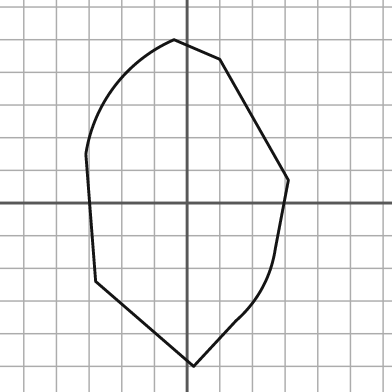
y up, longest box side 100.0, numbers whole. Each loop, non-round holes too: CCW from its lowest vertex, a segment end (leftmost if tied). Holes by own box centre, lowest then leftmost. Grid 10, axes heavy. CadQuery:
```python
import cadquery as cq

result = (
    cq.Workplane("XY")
    .moveTo(2.0, -50.0)
    .lineTo(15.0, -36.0)
    .threePointArc((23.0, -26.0), (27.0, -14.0))
    .lineTo(31.0, 7.0)
    .lineTo(10.0, 44.0)
    .lineTo(-4.0, 50.0)
    .threePointArc((-22.0, 36.0), (-31.0, 15.0))
    .lineTo(-28.0, -24.0)
    .close()
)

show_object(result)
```